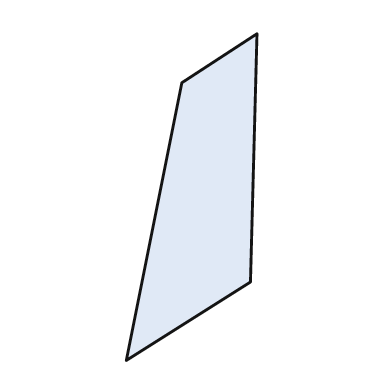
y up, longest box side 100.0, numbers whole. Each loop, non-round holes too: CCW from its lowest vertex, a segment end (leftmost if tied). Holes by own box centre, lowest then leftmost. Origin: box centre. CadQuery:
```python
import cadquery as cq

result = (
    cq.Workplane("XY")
    .moveTo(-20.0, -50.0)
    .lineTo(18.0, -26.0)
    .lineTo(20.0, 50.0)
    .lineTo(-3.0, 35.0)
    .close()
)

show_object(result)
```